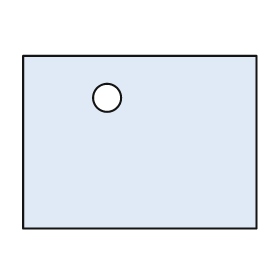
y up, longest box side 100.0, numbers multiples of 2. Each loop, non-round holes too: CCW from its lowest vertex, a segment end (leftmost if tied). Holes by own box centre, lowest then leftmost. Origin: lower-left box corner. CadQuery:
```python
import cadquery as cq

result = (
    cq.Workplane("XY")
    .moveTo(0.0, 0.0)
    .lineTo(100.0, 0.0)
    .lineTo(100.0, 74.0)
    .lineTo(0.0, 74.0)
    .close()
    .moveTo(36.0, 56.0)
    .circle(6.0)
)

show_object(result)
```